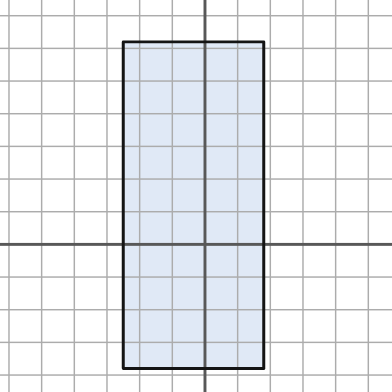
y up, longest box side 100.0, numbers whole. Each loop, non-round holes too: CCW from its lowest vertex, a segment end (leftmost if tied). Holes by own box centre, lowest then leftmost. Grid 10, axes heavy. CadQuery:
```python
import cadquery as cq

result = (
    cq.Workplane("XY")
    .moveTo(-25.0, -38.0)
    .lineTo(18.0, -38.0)
    .lineTo(18.0, 62.0)
    .lineTo(-25.0, 62.0)
    .close()
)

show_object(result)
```